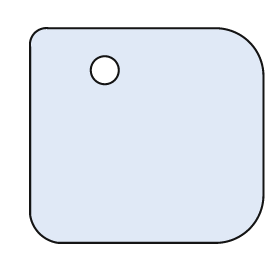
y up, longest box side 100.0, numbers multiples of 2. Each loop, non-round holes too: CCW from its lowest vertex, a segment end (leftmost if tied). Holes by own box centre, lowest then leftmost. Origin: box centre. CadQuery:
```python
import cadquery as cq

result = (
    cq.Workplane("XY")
    .moveTo(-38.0, -46.0)
    .lineTo(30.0, -46.0)
    .threePointArc((44.0, -40.0), (50.0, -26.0))
    .lineTo(50.0, 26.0)
    .threePointArc((44.0, 40.0), (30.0, 46.0))
    .lineTo(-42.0, 46.0)
    .threePointArc((-48.0, 44.0), (-50.0, 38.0))
    .lineTo(-50.0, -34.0)
    .threePointArc((-46.0, -42.0), (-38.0, -46.0))
    .close()
    .moveTo(-18.0, 28.0)
    .circle(6.0)
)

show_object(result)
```